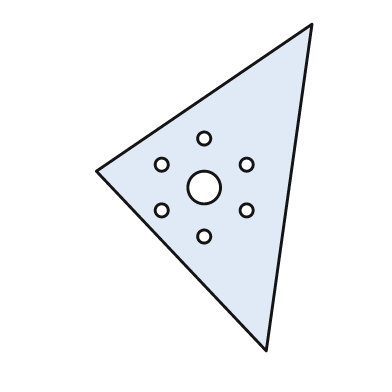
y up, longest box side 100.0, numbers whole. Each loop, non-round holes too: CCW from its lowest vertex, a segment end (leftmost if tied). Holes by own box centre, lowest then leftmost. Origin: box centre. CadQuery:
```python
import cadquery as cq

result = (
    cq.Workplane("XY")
    .moveTo(19.0, -50.0)
    .lineTo(33.0, 50.0)
    .lineTo(-33.0, 5.0)
    .close()
    .moveTo(0.0, -15.0)
    .circle(2.0)
    .moveTo(-13.0, -7.0)
    .circle(2.0)
    .moveTo(13.0, -7.0)
    .circle(2.0)
    .moveTo(0.0, 0.0)
    .circle(5.0)
    .moveTo(-13.0, 7.0)
    .circle(2.0)
    .moveTo(13.0, 7.0)
    .circle(2.0)
    .moveTo(0.0, 15.0)
    .circle(2.0)
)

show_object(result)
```